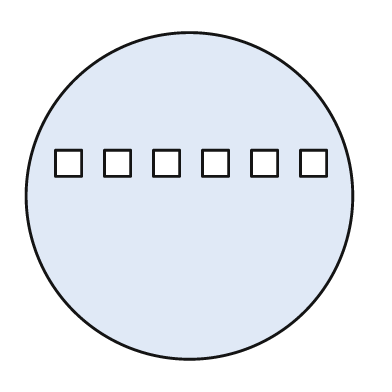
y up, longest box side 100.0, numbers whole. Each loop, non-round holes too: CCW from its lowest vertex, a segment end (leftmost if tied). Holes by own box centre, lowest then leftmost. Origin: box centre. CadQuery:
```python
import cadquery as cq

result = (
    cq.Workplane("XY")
    .moveTo(0.0, 0.0)
    .circle(50.0)
    .moveTo(-41.0, 6.0)
    .lineTo(-33.0, 6.0)
    .lineTo(-33.0, 14.0)
    .lineTo(-41.0, 14.0)
    .close()
    .moveTo(-26.0, 6.0)
    .lineTo(-18.0, 6.0)
    .lineTo(-18.0, 14.0)
    .lineTo(-26.0, 14.0)
    .close()
    .moveTo(-11.0, 6.0)
    .lineTo(-3.0, 6.0)
    .lineTo(-3.0, 14.0)
    .lineTo(-11.0, 14.0)
    .close()
    .moveTo(4.0, 6.0)
    .lineTo(12.0, 6.0)
    .lineTo(12.0, 14.0)
    .lineTo(4.0, 14.0)
    .close()
    .moveTo(19.0, 6.0)
    .lineTo(27.0, 6.0)
    .lineTo(27.0, 14.0)
    .lineTo(19.0, 14.0)
    .close()
    .moveTo(34.0, 6.0)
    .lineTo(42.0, 6.0)
    .lineTo(42.0, 14.0)
    .lineTo(34.0, 14.0)
    .close()
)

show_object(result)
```